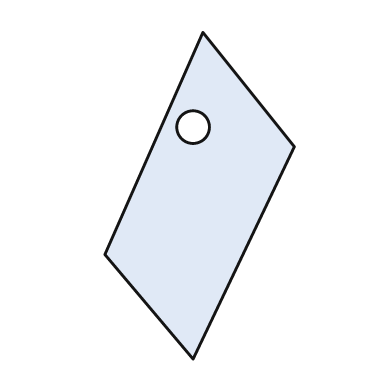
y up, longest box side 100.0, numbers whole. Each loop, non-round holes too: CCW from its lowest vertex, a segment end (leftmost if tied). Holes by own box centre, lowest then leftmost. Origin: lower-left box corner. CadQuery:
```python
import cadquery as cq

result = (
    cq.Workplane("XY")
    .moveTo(27.0, 0.0)
    .lineTo(58.0, 65.0)
    .lineTo(30.0, 100.0)
    .lineTo(0.0, 32.0)
    .close()
    .moveTo(27.0, 71.0)
    .circle(5.0)
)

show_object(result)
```